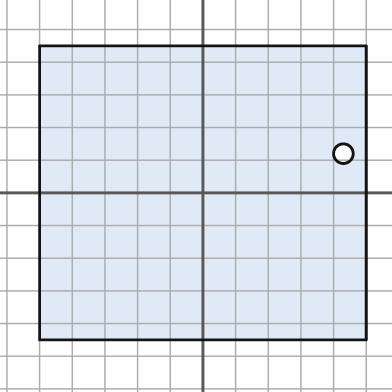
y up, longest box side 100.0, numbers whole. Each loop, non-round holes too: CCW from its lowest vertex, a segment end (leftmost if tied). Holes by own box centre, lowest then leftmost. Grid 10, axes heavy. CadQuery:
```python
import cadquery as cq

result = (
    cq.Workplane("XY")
    .moveTo(-50.0, -45.0)
    .lineTo(50.0, -45.0)
    .lineTo(50.0, 45.0)
    .lineTo(-50.0, 45.0)
    .close()
    .moveTo(43.0, 12.0)
    .circle(3.0)
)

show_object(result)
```